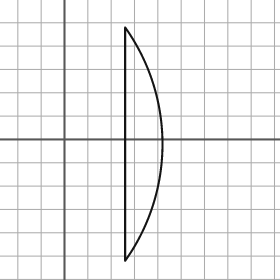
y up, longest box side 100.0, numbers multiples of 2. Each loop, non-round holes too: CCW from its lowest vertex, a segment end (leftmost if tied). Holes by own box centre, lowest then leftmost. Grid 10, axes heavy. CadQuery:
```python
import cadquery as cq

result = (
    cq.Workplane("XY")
    .moveTo(26.0, -52.0)
    .threePointArc((42.0, -2.0), (26.0, 48.0))
    .close()
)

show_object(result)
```